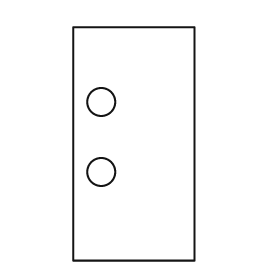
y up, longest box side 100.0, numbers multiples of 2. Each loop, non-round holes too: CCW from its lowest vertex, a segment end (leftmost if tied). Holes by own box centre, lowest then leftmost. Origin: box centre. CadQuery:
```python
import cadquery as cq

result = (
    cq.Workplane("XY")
    .moveTo(-26.0, -50.0)
    .lineTo(26.0, -50.0)
    .lineTo(26.0, 50.0)
    .lineTo(-26.0, 50.0)
    .close()
    .moveTo(-14.0, -12.0)
    .circle(6.0)
    .moveTo(-14.0, 18.0)
    .circle(6.0)
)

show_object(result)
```